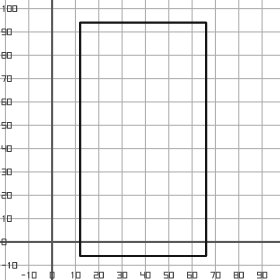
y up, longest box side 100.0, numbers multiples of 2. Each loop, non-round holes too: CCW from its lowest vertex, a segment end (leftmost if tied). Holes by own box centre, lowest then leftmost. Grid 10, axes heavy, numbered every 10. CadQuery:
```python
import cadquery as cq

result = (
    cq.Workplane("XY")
    .moveTo(12.0, -6.0)
    .lineTo(66.0, -6.0)
    .lineTo(66.0, 94.0)
    .lineTo(12.0, 94.0)
    .close()
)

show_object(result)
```